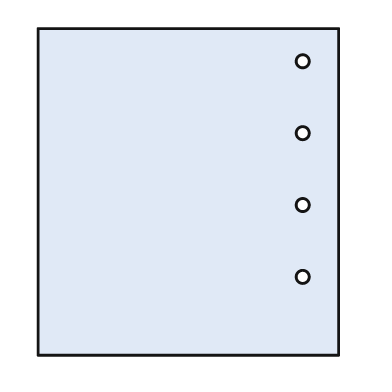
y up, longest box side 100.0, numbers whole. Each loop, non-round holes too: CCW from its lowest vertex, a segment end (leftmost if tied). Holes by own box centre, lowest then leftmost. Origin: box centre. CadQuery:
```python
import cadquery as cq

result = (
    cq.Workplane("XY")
    .moveTo(-46.0, -50.0)
    .lineTo(46.0, -50.0)
    .lineTo(46.0, 50.0)
    .lineTo(-46.0, 50.0)
    .close()
    .moveTo(35.0, -26.0)
    .circle(2.0)
    .moveTo(35.0, -4.0)
    .circle(2.0)
    .moveTo(35.0, 18.0)
    .circle(2.0)
    .moveTo(35.0, 40.0)
    .circle(2.0)
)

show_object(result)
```